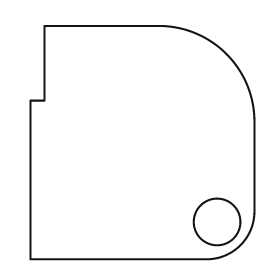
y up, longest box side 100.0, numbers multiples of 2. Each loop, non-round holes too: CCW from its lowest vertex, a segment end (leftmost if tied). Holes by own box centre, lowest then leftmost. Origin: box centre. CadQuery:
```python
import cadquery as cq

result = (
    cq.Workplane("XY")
    .moveTo(-48.0, -50.0)
    .lineTo(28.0, -50.0)
    .threePointArc((42.0, -44.0), (48.0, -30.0))
    .lineTo(48.0, 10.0)
    .threePointArc((36.0, 38.0), (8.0, 50.0))
    .lineTo(-42.0, 50.0)
    .lineTo(-42.0, 18.0)
    .lineTo(-48.0, 18.0)
    .close()
    .moveTo(32.0, -34.0)
    .circle(10.0)
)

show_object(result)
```